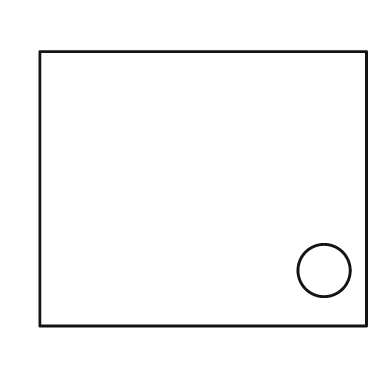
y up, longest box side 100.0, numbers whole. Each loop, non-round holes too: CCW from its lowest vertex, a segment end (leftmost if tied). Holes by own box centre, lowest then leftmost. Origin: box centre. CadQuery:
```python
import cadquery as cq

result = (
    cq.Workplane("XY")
    .moveTo(-50.0, -42.0)
    .lineTo(50.0, -42.0)
    .lineTo(50.0, 42.0)
    .lineTo(-50.0, 42.0)
    .close()
    .moveTo(37.0, -25.0)
    .circle(8.0)
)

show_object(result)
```